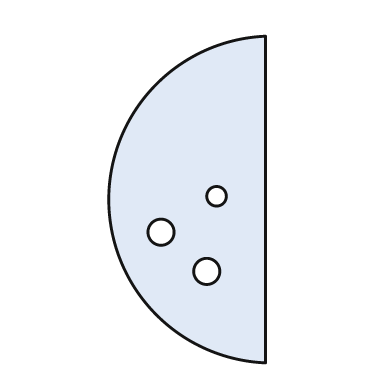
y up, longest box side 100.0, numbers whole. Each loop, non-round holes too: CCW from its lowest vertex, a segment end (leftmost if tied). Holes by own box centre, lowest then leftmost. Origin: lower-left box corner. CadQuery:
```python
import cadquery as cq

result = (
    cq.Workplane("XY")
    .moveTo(48.0, 0.0)
    .lineTo(48.0, 100.0)
    .threePointArc((0.0, 50.0), (48.0, 0.0))
    .close()
    .moveTo(30.0, 28.0)
    .circle(4.0)
    .moveTo(16.0, 40.0)
    .circle(4.0)
    .moveTo(33.0, 51.0)
    .circle(3.0)
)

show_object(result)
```